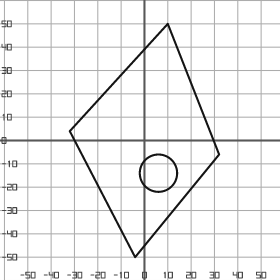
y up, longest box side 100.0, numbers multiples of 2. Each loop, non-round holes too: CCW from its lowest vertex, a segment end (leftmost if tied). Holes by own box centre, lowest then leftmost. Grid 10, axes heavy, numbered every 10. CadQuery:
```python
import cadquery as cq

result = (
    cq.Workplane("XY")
    .moveTo(-4.0, -50.0)
    .lineTo(32.0, -6.0)
    .lineTo(10.0, 50.0)
    .lineTo(-32.0, 4.0)
    .close()
    .moveTo(6.0, -14.0)
    .circle(8.0)
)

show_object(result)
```